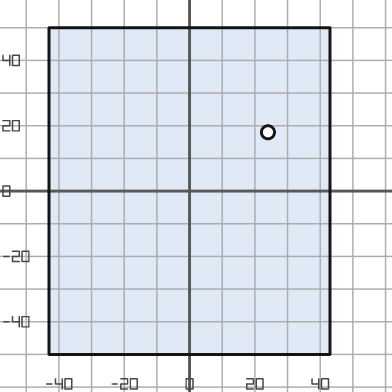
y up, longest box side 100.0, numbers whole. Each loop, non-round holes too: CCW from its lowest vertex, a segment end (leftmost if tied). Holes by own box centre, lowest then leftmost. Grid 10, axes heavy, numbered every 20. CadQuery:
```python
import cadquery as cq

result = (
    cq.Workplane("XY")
    .moveTo(-43.0, -50.0)
    .lineTo(43.0, -50.0)
    .lineTo(43.0, 50.0)
    .lineTo(-43.0, 50.0)
    .close()
    .moveTo(24.0, 18.0)
    .circle(2.0)
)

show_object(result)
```